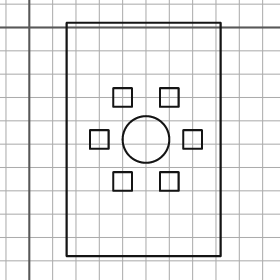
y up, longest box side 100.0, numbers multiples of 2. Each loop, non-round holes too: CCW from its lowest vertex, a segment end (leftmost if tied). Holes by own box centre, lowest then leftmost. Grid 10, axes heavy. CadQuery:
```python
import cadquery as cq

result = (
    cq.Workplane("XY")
    .moveTo(16.0, -98.0)
    .lineTo(82.0, -98.0)
    .lineTo(82.0, 2.0)
    .lineTo(16.0, 2.0)
    .close()
    .moveTo(36.0, -70.0)
    .lineTo(44.0, -70.0)
    .lineTo(44.0, -62.0)
    .lineTo(36.0, -62.0)
    .close()
    .moveTo(56.0, -70.0)
    .lineTo(64.0, -70.0)
    .lineTo(64.0, -62.0)
    .lineTo(56.0, -62.0)
    .close()
    .moveTo(26.0, -52.0)
    .lineTo(34.0, -52.0)
    .lineTo(34.0, -44.0)
    .lineTo(26.0, -44.0)
    .close()
    .moveTo(50.0, -48.0)
    .circle(10.0)
    .moveTo(66.0, -52.0)
    .lineTo(74.0, -52.0)
    .lineTo(74.0, -44.0)
    .lineTo(66.0, -44.0)
    .close()
    .moveTo(36.0, -34.0)
    .lineTo(44.0, -34.0)
    .lineTo(44.0, -26.0)
    .lineTo(36.0, -26.0)
    .close()
    .moveTo(56.0, -34.0)
    .lineTo(64.0, -34.0)
    .lineTo(64.0, -26.0)
    .lineTo(56.0, -26.0)
    .close()
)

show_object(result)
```